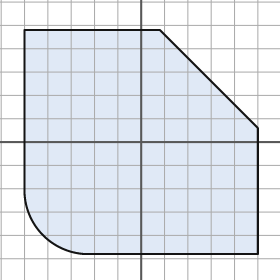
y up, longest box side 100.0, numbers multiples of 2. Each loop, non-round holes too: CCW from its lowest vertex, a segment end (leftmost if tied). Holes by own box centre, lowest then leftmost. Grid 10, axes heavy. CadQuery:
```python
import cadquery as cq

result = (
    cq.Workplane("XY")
    .moveTo(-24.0, -48.0)
    .lineTo(50.0, -48.0)
    .lineTo(50.0, 6.0)
    .lineTo(8.0, 48.0)
    .lineTo(-50.0, 48.0)
    .lineTo(-50.0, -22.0)
    .threePointArc((-42.0, -40.0), (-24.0, -48.0))
    .close()
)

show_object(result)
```